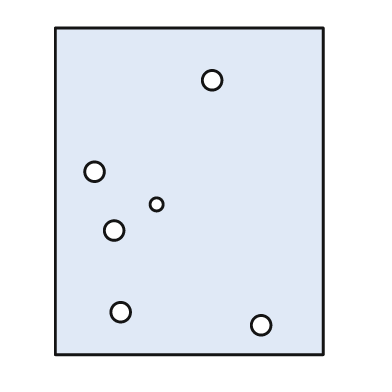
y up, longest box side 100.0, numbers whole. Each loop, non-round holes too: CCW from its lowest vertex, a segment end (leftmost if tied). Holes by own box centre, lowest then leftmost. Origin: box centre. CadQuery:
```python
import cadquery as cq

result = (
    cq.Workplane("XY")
    .moveTo(-41.0, -50.0)
    .lineTo(41.0, -50.0)
    .lineTo(41.0, 50.0)
    .lineTo(-41.0, 50.0)
    .close()
    .moveTo(22.0, -41.0)
    .circle(3.0)
    .moveTo(-21.0, -37.0)
    .circle(3.0)
    .moveTo(-23.0, -12.0)
    .circle(3.0)
    .moveTo(-10.0, -4.0)
    .circle(2.0)
    .moveTo(-29.0, 6.0)
    .circle(3.0)
    .moveTo(7.0, 34.0)
    .circle(3.0)
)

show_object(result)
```